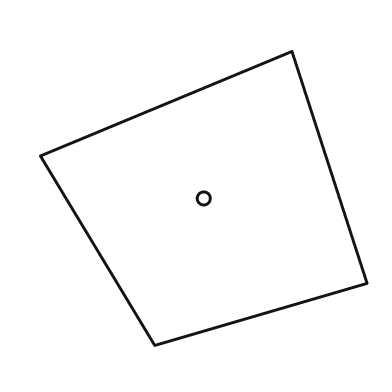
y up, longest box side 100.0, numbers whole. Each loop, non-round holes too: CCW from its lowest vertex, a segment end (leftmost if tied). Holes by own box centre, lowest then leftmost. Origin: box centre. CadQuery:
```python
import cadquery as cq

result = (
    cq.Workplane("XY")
    .moveTo(-15.0, -45.0)
    .lineTo(50.0, -26.0)
    .lineTo(27.0, 45.0)
    .lineTo(-50.0, 13.0)
    .close()
    .moveTo(0.0, 0.0)
    .circle(2.0)
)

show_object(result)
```